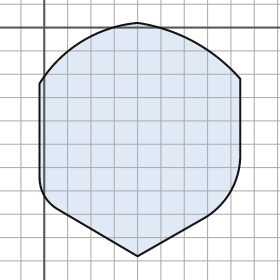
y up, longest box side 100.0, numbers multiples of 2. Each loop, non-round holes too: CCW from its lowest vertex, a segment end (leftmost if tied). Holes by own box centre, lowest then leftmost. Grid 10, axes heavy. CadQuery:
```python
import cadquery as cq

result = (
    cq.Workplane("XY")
    .moveTo(40.0, -98.0)
    .lineTo(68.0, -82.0)
    .threePointArc((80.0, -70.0), (84.0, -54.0))
    .lineTo(84.0, -22.0)
    .threePointArc((64.0, -6.0), (40.0, 2.0))
    .threePointArc((16.0, -6.0), (-2.0, -24.0))
    .lineTo(-2.0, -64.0)
    .threePointArc((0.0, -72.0), (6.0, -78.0))
    .close()
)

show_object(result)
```